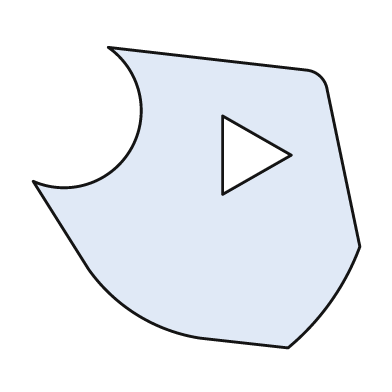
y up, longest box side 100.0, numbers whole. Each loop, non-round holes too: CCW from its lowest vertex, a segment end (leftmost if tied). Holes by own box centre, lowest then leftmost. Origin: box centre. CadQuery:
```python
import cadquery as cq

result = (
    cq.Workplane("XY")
    .moveTo(28.0, -46.0)
    .threePointArc((41.0, -32.0), (50.0, -15.0))
    .lineTo(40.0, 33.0)
    .threePointArc((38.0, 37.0), (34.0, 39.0))
    .lineTo(-27.0, 46.0)
    .threePointArc((-20.0, 15.0), (-50.0, 5.0))
    .lineTo(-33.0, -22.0)
    .threePointArc((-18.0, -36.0), (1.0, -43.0))
    .close()
    .moveTo(8.0, 1.0)
    .lineTo(29.0, 13.0)
    .lineTo(8.0, 25.0)
    .close()
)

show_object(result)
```